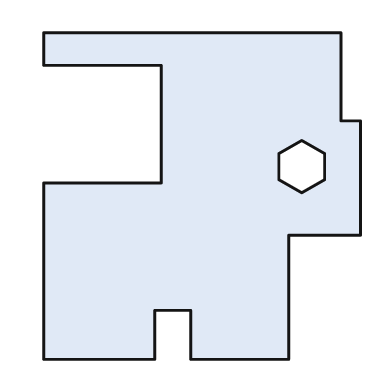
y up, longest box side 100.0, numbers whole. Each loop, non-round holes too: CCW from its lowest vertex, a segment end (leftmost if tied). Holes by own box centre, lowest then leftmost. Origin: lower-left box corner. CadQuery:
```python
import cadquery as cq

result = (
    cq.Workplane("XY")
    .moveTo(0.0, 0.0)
    .lineTo(34.0, 0.0)
    .lineTo(34.0, 15.0)
    .lineTo(45.0, 15.0)
    .lineTo(45.0, 0.0)
    .lineTo(75.0, 0.0)
    .lineTo(75.0, 38.0)
    .lineTo(97.0, 38.0)
    .lineTo(97.0, 73.0)
    .lineTo(91.0, 73.0)
    .lineTo(91.0, 100.0)
    .lineTo(0.0, 100.0)
    .lineTo(0.0, 90.0)
    .lineTo(36.0, 90.0)
    .lineTo(36.0, 54.0)
    .lineTo(0.0, 54.0)
    .close()
    .moveTo(79.0, 51.0)
    .lineTo(86.0, 55.0)
    .lineTo(86.0, 63.0)
    .lineTo(79.0, 67.0)
    .lineTo(72.0, 63.0)
    .lineTo(72.0, 55.0)
    .close()
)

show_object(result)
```